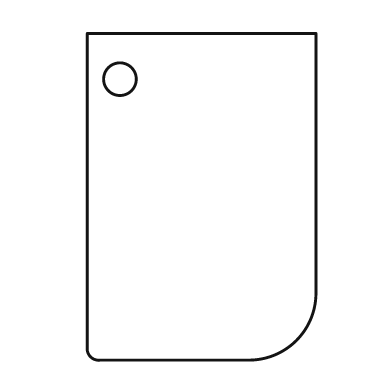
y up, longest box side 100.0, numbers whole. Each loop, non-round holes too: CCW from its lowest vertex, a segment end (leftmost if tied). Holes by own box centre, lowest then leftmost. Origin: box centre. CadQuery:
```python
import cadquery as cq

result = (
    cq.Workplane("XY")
    .moveTo(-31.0, -50.0)
    .lineTo(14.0, -50.0)
    .threePointArc((29.0, -44.0), (35.0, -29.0))
    .lineTo(35.0, 50.0)
    .lineTo(-35.0, 50.0)
    .lineTo(-35.0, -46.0)
    .threePointArc((-34.0, -49.0), (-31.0, -50.0))
    .close()
    .moveTo(-25.0, 36.0)
    .circle(5.0)
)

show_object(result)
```